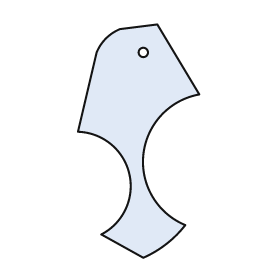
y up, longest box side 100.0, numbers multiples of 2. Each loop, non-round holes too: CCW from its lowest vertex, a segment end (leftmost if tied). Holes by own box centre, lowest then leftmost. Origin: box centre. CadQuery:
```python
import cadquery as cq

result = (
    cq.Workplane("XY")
    .moveTo(2.0, -50.0)
    .threePointArc((12.0, -44.0), (20.0, -36.0))
    .threePointArc((2.0, -6.0), (26.0, 20.0))
    .lineTo(8.0, 50.0)
    .lineTo(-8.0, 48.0)
    .threePointArc((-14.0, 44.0), (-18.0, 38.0))
    .lineTo(-26.0, 4.0)
    .threePointArc((-4.0, -14.0), (-16.0, -40.0))
    .close()
    .moveTo(2.0, 38.0)
    .circle(2.0)
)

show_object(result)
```